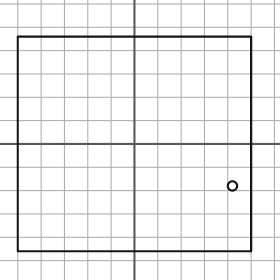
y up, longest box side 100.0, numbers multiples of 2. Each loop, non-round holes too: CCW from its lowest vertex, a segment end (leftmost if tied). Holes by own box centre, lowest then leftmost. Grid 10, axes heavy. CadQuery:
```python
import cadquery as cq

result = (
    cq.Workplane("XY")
    .moveTo(-50.0, -46.0)
    .lineTo(50.0, -46.0)
    .lineTo(50.0, 46.0)
    .lineTo(-50.0, 46.0)
    .close()
    .moveTo(42.0, -18.0)
    .circle(2.0)
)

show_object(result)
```